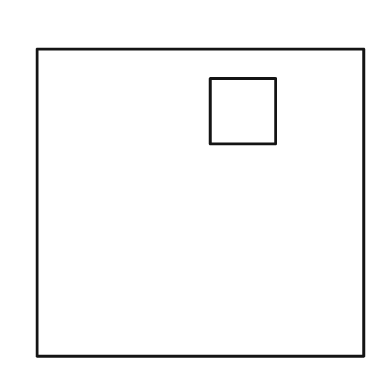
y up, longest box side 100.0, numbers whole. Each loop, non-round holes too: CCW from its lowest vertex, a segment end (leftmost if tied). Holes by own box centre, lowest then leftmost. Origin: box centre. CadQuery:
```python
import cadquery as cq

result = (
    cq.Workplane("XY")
    .moveTo(-50.0, -47.0)
    .lineTo(50.0, -47.0)
    .lineTo(50.0, 47.0)
    .lineTo(-50.0, 47.0)
    .close()
    .moveTo(3.0, 18.0)
    .lineTo(23.0, 18.0)
    .lineTo(23.0, 38.0)
    .lineTo(3.0, 38.0)
    .close()
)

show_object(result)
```